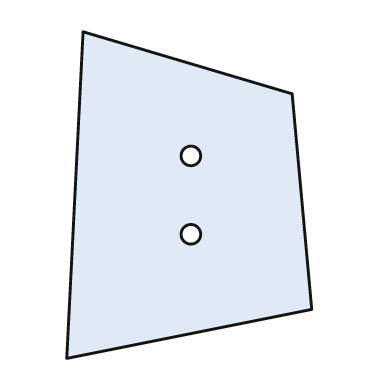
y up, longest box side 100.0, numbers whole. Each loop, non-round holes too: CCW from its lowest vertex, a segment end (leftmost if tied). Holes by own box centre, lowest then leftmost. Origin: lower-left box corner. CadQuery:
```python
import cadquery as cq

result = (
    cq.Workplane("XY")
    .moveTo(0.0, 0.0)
    .lineTo(75.0, 15.0)
    .lineTo(69.0, 81.0)
    .lineTo(5.0, 100.0)
    .close()
    .moveTo(38.0, 38.0)
    .circle(3.0)
    .moveTo(38.0, 62.0)
    .circle(3.0)
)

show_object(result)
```